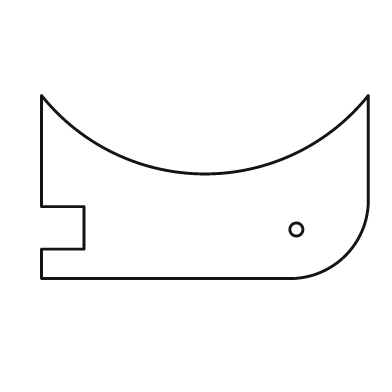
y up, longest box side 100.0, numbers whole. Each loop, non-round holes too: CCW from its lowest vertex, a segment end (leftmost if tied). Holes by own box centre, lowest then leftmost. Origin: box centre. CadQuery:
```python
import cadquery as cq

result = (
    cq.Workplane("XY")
    .moveTo(-50.0, -28.0)
    .lineTo(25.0, -28.0)
    .threePointArc((43.0, -21.0), (50.0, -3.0))
    .lineTo(50.0, 28.0)
    .threePointArc((0.0, 4.0), (-50.0, 28.0))
    .lineTo(-50.0, -6.0)
    .lineTo(-37.0, -6.0)
    .lineTo(-37.0, -19.0)
    .lineTo(-50.0, -19.0)
    .close()
    .moveTo(28.0, -13.0)
    .circle(2.0)
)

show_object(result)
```